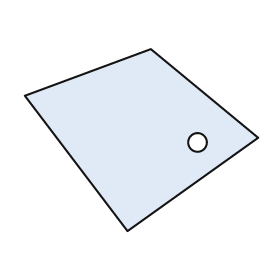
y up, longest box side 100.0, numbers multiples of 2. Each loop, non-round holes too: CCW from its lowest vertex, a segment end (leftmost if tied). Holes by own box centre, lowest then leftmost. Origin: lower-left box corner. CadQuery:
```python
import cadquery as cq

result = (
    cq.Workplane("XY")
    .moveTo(44.0, 0.0)
    .lineTo(100.0, 40.0)
    .lineTo(54.0, 78.0)
    .lineTo(0.0, 58.0)
    .close()
    .moveTo(74.0, 38.0)
    .circle(4.0)
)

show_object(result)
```